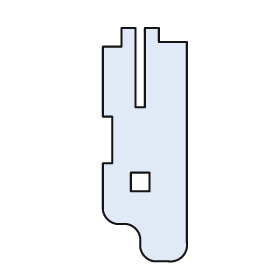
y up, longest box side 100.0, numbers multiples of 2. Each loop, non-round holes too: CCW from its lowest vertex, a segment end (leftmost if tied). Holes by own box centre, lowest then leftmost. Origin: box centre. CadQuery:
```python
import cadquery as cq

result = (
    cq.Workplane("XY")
    .moveTo(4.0, -50.0)
    .lineTo(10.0, -50.0)
    .threePointArc((16.0, -48.0), (18.0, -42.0))
    .lineTo(18.0, 44.0)
    .lineTo(6.0, 44.0)
    .lineTo(6.0, 50.0)
    .lineTo(0.0, 50.0)
    .lineTo(0.0, 16.0)
    .lineTo(-4.0, 16.0)
    .lineTo(-4.0, 50.0)
    .lineTo(-10.0, 50.0)
    .lineTo(-10.0, 42.0)
    .lineTo(-18.0, 42.0)
    .lineTo(-18.0, 12.0)
    .lineTo(-14.0, 12.0)
    .lineTo(-14.0, -8.0)
    .lineTo(-18.0, -8.0)
    .lineTo(-18.0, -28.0)
    .threePointArc((-16.0, -32.0), (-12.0, -34.0))
    .lineTo(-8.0, -34.0)
    .threePointArc((-4.0, -36.0), (-2.0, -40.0))
    .lineTo(-2.0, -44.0)
    .threePointArc((0.0, -48.0), (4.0, -50.0))
    .close()
    .moveTo(-6.0, -20.0)
    .lineTo(2.0, -20.0)
    .lineTo(2.0, -12.0)
    .lineTo(-6.0, -12.0)
    .close()
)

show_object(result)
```